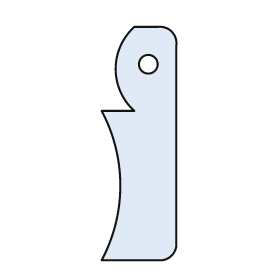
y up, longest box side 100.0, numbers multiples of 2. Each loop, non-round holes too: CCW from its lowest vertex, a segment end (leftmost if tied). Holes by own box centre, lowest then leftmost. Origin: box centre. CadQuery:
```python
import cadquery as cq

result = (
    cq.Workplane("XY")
    .moveTo(-16.0, -50.0)
    .lineTo(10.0, -50.0)
    .threePointArc((14.0, -48.0), (16.0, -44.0))
    .lineTo(16.0, 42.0)
    .threePointArc((14.0, 48.0), (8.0, 50.0))
    .lineTo(-2.0, 50.0)
    .threePointArc((-10.0, 32.0), (-2.0, 14.0))
    .lineTo(-16.0, 14.0)
    .threePointArc((-8.0, -18.0), (-16.0, -50.0))
    .close()
    .moveTo(4.0, 34.0)
    .circle(4.0)
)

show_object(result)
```